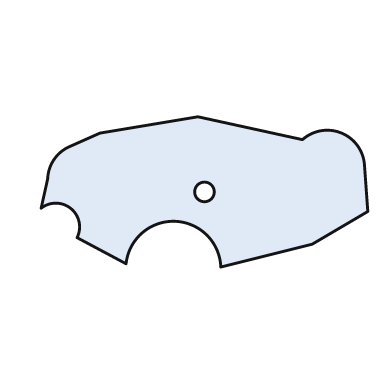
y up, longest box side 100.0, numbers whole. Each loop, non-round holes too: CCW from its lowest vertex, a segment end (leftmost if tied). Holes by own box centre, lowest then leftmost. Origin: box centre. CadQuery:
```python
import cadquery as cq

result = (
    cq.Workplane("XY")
    .moveTo(5.0, -23.0)
    .lineTo(33.0, -16.0)
    .lineTo(50.0, -6.0)
    .lineTo(49.0, 8.0)
    .threePointArc((42.0, 18.0), (30.0, 16.0))
    .lineTo(-2.0, 23.0)
    .lineTo(-32.0, 18.0)
    .lineTo(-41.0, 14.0)
    .threePointArc((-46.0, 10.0), (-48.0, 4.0))
    .lineTo(-50.0, -5.0)
    .threePointArc((-41.0, -5.0), (-39.0, -14.0))
    .lineTo(-24.0, -22.0)
    .threePointArc((-9.0, -9.0), (5.0, -23.0))
    .close()
    .moveTo(0.0, 0.0)
    .circle(3.0)
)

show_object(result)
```